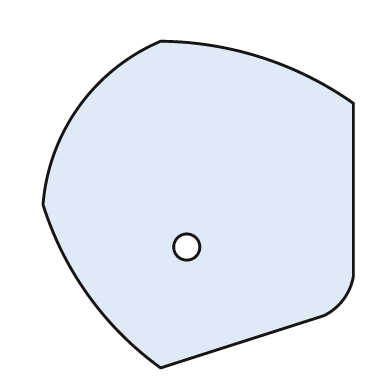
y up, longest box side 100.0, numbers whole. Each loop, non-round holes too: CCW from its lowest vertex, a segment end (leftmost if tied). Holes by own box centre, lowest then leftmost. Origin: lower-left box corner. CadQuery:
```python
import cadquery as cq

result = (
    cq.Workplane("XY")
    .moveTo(36.0, 0.0)
    .lineTo(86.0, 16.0)
    .threePointArc((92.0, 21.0), (95.0, 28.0))
    .lineTo(95.0, 81.0)
    .threePointArc((67.0, 95.0), (36.0, 100.0))
    .threePointArc((11.0, 80.0), (0.0, 50.0))
    .threePointArc((14.0, 22.0), (36.0, 0.0))
    .close()
    .moveTo(44.0, 37.0)
    .circle(4.0)
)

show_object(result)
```